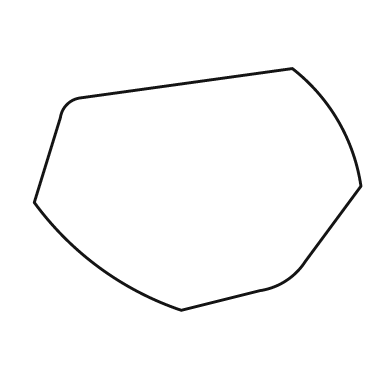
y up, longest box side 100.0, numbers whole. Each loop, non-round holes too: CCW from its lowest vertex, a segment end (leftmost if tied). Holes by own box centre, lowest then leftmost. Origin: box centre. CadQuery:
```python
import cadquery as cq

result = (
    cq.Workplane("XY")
    .moveTo(-5.0, -37.0)
    .lineTo(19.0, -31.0)
    .threePointArc((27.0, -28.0), (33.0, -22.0))
    .lineTo(50.0, 1.0)
    .threePointArc((43.0, 21.0), (29.0, 37.0))
    .lineTo(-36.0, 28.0)
    .threePointArc((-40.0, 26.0), (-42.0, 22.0))
    .lineTo(-50.0, -4.0)
    .threePointArc((-30.0, -24.0), (-5.0, -37.0))
    .close()
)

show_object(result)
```